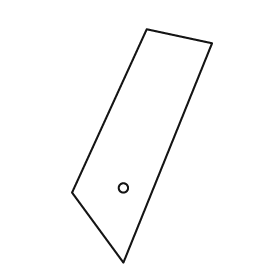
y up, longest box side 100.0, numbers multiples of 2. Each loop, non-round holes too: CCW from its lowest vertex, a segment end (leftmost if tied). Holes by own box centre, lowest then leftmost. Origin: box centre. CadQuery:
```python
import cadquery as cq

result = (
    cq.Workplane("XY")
    .moveTo(-8.0, -50.0)
    .lineTo(30.0, 44.0)
    .lineTo(2.0, 50.0)
    .lineTo(-30.0, -20.0)
    .close()
    .moveTo(-8.0, -18.0)
    .circle(2.0)
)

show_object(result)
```